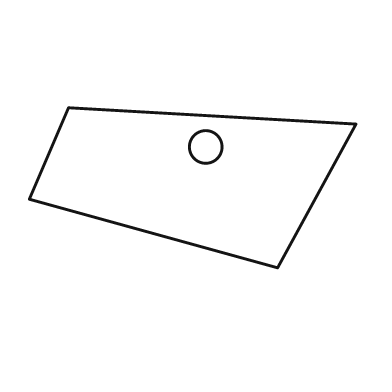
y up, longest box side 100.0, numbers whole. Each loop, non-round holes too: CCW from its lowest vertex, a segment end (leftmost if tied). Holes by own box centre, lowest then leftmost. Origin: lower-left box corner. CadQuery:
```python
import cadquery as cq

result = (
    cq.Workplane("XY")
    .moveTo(76.0, 0.0)
    .lineTo(100.0, 44.0)
    .lineTo(12.0, 49.0)
    .lineTo(0.0, 21.0)
    .close()
    .moveTo(54.0, 37.0)
    .circle(5.0)
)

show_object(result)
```